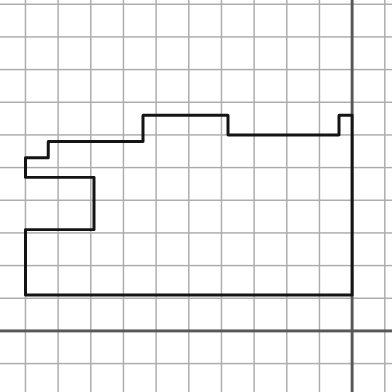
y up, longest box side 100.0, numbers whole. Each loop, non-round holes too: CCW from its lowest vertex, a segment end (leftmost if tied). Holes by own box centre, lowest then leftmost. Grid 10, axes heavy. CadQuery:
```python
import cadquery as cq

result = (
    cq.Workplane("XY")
    .moveTo(-100.0, 11.0)
    .lineTo(0.0, 11.0)
    .lineTo(0.0, 66.0)
    .lineTo(-4.0, 66.0)
    .lineTo(-4.0, 60.0)
    .lineTo(-38.0, 60.0)
    .lineTo(-38.0, 66.0)
    .lineTo(-64.0, 66.0)
    .lineTo(-64.0, 58.0)
    .lineTo(-93.0, 58.0)
    .lineTo(-93.0, 53.0)
    .lineTo(-100.0, 53.0)
    .lineTo(-100.0, 47.0)
    .lineTo(-79.0, 47.0)
    .lineTo(-79.0, 31.0)
    .lineTo(-100.0, 31.0)
    .close()
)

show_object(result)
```